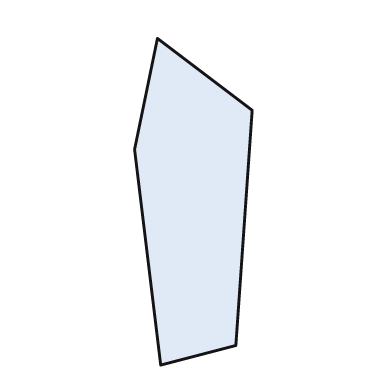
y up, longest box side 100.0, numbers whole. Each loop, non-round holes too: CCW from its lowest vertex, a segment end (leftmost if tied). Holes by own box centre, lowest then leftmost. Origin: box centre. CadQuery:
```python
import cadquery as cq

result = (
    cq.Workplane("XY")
    .moveTo(-10.0, -50.0)
    .lineTo(13.0, -44.0)
    .lineTo(18.0, 28.0)
    .lineTo(-11.0, 50.0)
    .lineTo(-18.0, 16.0)
    .close()
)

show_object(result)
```